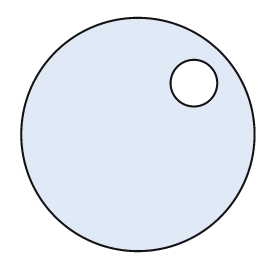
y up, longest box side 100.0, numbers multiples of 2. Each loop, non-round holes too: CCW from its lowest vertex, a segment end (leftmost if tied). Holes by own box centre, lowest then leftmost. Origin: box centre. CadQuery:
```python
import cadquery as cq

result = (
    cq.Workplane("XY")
    .moveTo(0.0, 0.0)
    .circle(50.0)
    .moveTo(24.0, 22.0)
    .circle(10.0)
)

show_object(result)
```